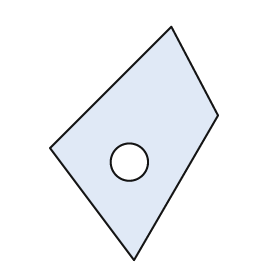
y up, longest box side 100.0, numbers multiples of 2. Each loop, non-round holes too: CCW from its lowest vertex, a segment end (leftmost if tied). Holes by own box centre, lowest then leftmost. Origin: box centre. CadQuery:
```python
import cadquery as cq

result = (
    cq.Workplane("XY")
    .moveTo(0.0, -50.0)
    .lineTo(36.0, 12.0)
    .lineTo(16.0, 50.0)
    .lineTo(-36.0, -2.0)
    .close()
    .moveTo(-2.0, -8.0)
    .circle(8.0)
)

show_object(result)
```